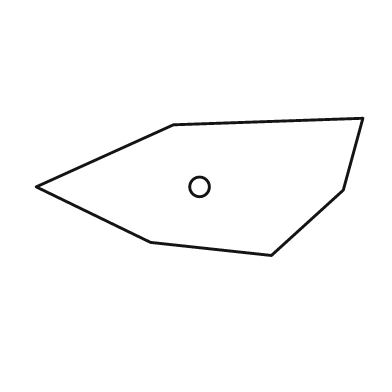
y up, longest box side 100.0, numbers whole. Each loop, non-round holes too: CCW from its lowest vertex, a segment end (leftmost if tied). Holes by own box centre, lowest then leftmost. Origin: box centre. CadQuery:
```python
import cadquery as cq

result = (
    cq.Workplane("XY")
    .moveTo(22.0, -21.0)
    .lineTo(44.0, -1.0)
    .lineTo(50.0, 21.0)
    .lineTo(-8.0, 19.0)
    .lineTo(-50.0, 0.0)
    .lineTo(-15.0, -17.0)
    .close()
    .moveTo(0.0, 0.0)
    .circle(3.0)
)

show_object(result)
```